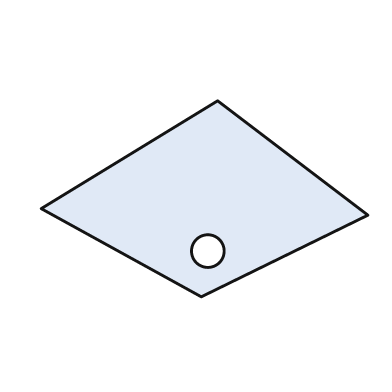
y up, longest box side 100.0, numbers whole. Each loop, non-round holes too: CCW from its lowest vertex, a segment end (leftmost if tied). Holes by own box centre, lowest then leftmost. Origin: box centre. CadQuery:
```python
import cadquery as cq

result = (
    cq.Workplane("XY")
    .moveTo(-1.0, -30.0)
    .lineTo(50.0, -5.0)
    .lineTo(4.0, 30.0)
    .lineTo(-50.0, -3.0)
    .close()
    .moveTo(1.0, -16.0)
    .circle(5.0)
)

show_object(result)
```